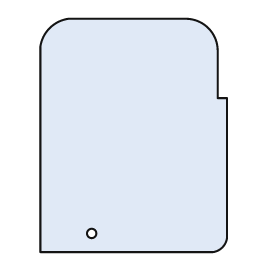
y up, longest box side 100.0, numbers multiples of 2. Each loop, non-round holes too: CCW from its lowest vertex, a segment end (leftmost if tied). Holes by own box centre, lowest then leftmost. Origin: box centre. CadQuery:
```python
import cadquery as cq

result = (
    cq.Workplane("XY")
    .moveTo(-40.0, -50.0)
    .lineTo(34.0, -50.0)
    .threePointArc((38.0, -48.0), (40.0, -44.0))
    .lineTo(40.0, 16.0)
    .lineTo(36.0, 16.0)
    .lineTo(36.0, 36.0)
    .threePointArc((32.0, 46.0), (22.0, 50.0))
    .lineTo(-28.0, 50.0)
    .threePointArc((-36.0, 46.0), (-40.0, 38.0))
    .close()
    .moveTo(-18.0, -42.0)
    .circle(2.0)
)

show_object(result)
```